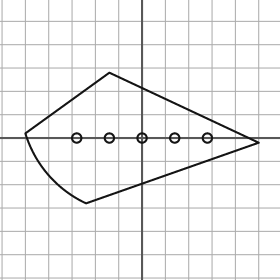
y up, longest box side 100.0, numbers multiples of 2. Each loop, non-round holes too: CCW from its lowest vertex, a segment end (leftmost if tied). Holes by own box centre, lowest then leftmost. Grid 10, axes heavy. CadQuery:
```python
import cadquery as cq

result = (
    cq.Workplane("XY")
    .moveTo(-24.0, -28.0)
    .lineTo(50.0, -2.0)
    .lineTo(-14.0, 28.0)
    .lineTo(-50.0, 2.0)
    .threePointArc((-40.0, -16.0), (-24.0, -28.0))
    .close()
    .moveTo(-28.0, 0.0)
    .circle(2.0)
    .moveTo(-14.0, 0.0)
    .circle(2.0)
    .moveTo(0.0, 0.0)
    .circle(2.0)
    .moveTo(14.0, 0.0)
    .circle(2.0)
    .moveTo(28.0, 0.0)
    .circle(2.0)
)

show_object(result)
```